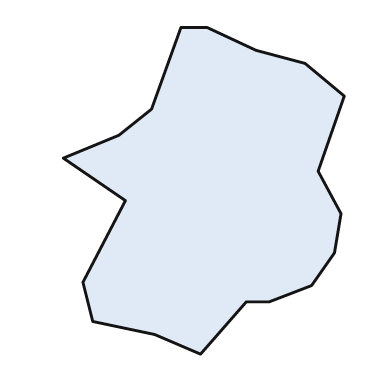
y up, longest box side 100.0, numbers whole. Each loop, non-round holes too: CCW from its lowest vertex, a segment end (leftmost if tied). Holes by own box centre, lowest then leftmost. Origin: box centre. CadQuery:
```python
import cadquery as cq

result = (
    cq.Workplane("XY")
    .moveTo(-1.0, -50.0)
    .lineTo(13.0, -34.0)
    .lineTo(20.0, -34.0)
    .lineTo(33.0, -29.0)
    .lineTo(40.0, -19.0)
    .lineTo(42.0, -7.0)
    .lineTo(35.0, 6.0)
    .lineTo(43.0, 29.0)
    .lineTo(31.0, 39.0)
    .lineTo(16.0, 43.0)
    .lineTo(1.0, 50.0)
    .lineTo(-7.0, 50.0)
    .lineTo(-16.0, 25.0)
    .lineTo(-26.0, 17.0)
    .lineTo(-43.0, 10.0)
    .lineTo(-24.0, -3.0)
    .lineTo(-37.0, -28.0)
    .lineTo(-34.0, -40.0)
    .lineTo(-15.0, -44.0)
    .close()
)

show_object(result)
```